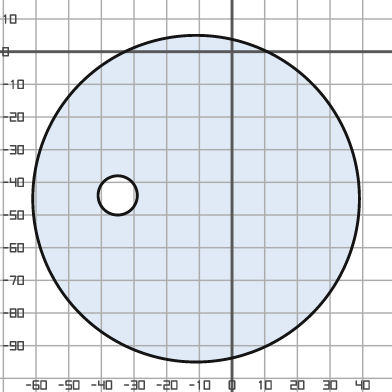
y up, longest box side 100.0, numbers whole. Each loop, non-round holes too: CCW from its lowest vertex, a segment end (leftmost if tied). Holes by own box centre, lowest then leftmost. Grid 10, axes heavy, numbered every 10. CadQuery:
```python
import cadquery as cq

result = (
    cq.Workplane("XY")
    .moveTo(-11.0, -45.0)
    .circle(50.0)
    .moveTo(-35.0, -44.0)
    .circle(6.0)
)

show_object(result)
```